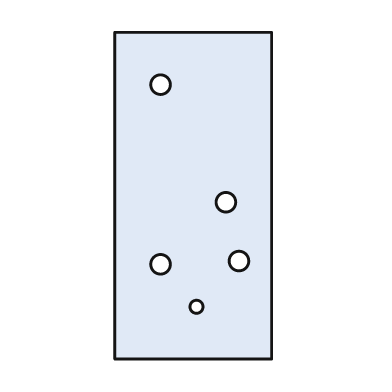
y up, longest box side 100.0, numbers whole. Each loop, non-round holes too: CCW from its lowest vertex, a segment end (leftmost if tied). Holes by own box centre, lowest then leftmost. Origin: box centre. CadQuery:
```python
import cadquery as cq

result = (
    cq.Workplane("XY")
    .moveTo(-24.0, -50.0)
    .lineTo(24.0, -50.0)
    .lineTo(24.0, 50.0)
    .lineTo(-24.0, 50.0)
    .close()
    .moveTo(1.0, -34.0)
    .circle(2.0)
    .moveTo(-10.0, -21.0)
    .circle(3.0)
    .moveTo(14.0, -20.0)
    .circle(3.0)
    .moveTo(10.0, -2.0)
    .circle(3.0)
    .moveTo(-10.0, 34.0)
    .circle(3.0)
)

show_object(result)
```